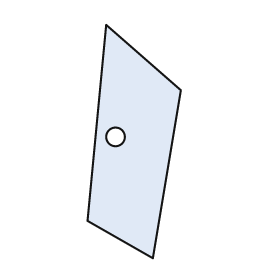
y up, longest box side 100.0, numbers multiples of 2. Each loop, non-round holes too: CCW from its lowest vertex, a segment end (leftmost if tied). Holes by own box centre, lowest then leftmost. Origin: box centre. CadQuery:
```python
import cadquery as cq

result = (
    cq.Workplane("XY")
    .moveTo(8.0, -50.0)
    .lineTo(20.0, 22.0)
    .lineTo(-12.0, 50.0)
    .lineTo(-20.0, -34.0)
    .close()
    .moveTo(-8.0, 2.0)
    .circle(4.0)
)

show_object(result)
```